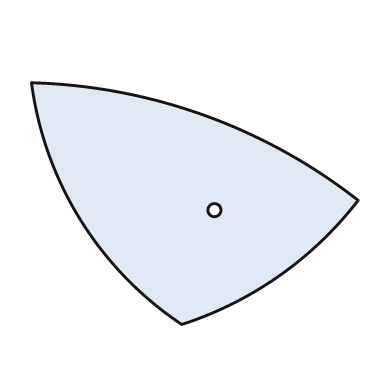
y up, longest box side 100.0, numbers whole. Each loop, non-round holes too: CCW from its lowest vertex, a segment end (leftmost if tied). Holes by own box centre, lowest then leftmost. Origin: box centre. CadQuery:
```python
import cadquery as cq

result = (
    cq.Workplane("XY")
    .moveTo(-4.0, -37.0)
    .threePointArc((26.0, -22.0), (50.0, 1.0))
    .threePointArc((3.0, 27.0), (-50.0, 37.0))
    .threePointArc((-35.0, -5.0), (-4.0, -37.0))
    .close()
    .moveTo(6.0, -2.0)
    .circle(2.0)
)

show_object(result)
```